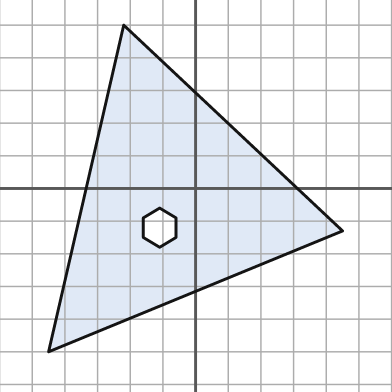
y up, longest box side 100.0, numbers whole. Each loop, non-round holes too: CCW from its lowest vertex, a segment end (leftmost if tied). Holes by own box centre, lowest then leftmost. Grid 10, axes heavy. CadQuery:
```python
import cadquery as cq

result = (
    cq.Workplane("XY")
    .moveTo(-45.0, -50.0)
    .lineTo(45.0, -13.0)
    .lineTo(-22.0, 50.0)
    .close()
    .moveTo(-11.0, -18.0)
    .lineTo(-6.0, -15.0)
    .lineTo(-6.0, -9.0)
    .lineTo(-11.0, -6.0)
    .lineTo(-16.0, -9.0)
    .lineTo(-16.0, -15.0)
    .close()
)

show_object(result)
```